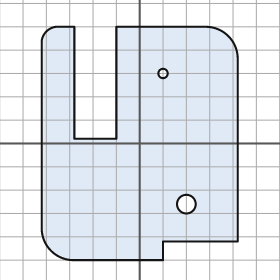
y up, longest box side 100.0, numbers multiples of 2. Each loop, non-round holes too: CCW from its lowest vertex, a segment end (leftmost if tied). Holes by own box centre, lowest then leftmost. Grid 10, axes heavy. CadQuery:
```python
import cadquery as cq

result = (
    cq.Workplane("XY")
    .moveTo(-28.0, -50.0)
    .lineTo(10.0, -50.0)
    .lineTo(10.0, -42.0)
    .lineTo(42.0, -42.0)
    .lineTo(42.0, 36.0)
    .threePointArc((38.0, 46.0), (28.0, 50.0))
    .lineTo(-10.0, 50.0)
    .lineTo(-10.0, 2.0)
    .lineTo(-28.0, 2.0)
    .lineTo(-28.0, 50.0)
    .lineTo(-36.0, 50.0)
    .threePointArc((-40.0, 48.0), (-42.0, 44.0))
    .lineTo(-42.0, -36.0)
    .threePointArc((-38.0, -46.0), (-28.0, -50.0))
    .close()
    .moveTo(20.0, -26.0)
    .circle(4.0)
    .moveTo(10.0, 30.0)
    .circle(2.0)
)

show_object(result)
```